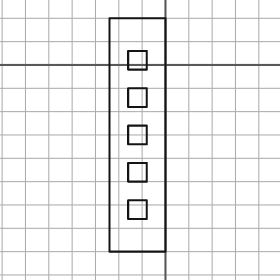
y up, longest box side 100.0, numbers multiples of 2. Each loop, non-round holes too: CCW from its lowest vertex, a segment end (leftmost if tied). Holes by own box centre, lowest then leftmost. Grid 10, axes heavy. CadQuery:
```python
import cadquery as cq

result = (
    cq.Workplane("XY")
    .moveTo(-24.0, -80.0)
    .lineTo(0.0, -80.0)
    .lineTo(0.0, 20.0)
    .lineTo(-24.0, 20.0)
    .close()
    .moveTo(-16.0, -66.0)
    .lineTo(-8.0, -66.0)
    .lineTo(-8.0, -58.0)
    .lineTo(-16.0, -58.0)
    .close()
    .moveTo(-16.0, -50.0)
    .lineTo(-8.0, -50.0)
    .lineTo(-8.0, -42.0)
    .lineTo(-16.0, -42.0)
    .close()
    .moveTo(-16.0, -34.0)
    .lineTo(-8.0, -34.0)
    .lineTo(-8.0, -26.0)
    .lineTo(-16.0, -26.0)
    .close()
    .moveTo(-16.0, -18.0)
    .lineTo(-8.0, -18.0)
    .lineTo(-8.0, -10.0)
    .lineTo(-16.0, -10.0)
    .close()
    .moveTo(-16.0, -2.0)
    .lineTo(-8.0, -2.0)
    .lineTo(-8.0, 6.0)
    .lineTo(-16.0, 6.0)
    .close()
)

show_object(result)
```